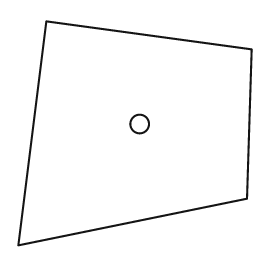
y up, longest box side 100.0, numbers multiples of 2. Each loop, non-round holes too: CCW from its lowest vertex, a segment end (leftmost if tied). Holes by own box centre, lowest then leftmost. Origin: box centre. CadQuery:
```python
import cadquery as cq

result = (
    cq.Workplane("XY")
    .moveTo(-50.0, -48.0)
    .lineTo(48.0, -28.0)
    .lineTo(50.0, 36.0)
    .lineTo(-38.0, 48.0)
    .close()
    .moveTo(2.0, 4.0)
    .circle(4.0)
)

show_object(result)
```